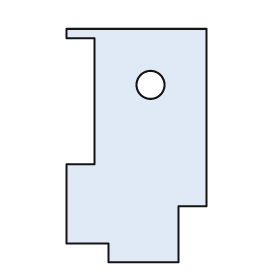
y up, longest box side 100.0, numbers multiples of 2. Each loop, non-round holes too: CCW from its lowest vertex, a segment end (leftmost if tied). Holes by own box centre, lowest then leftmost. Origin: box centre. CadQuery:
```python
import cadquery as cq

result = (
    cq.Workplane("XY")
    .moveTo(-12.0, -50.0)
    .lineTo(18.0, -50.0)
    .lineTo(18.0, -26.0)
    .lineTo(30.0, -26.0)
    .lineTo(30.0, 50.0)
    .lineTo(-30.0, 50.0)
    .lineTo(-30.0, 46.0)
    .lineTo(-18.0, 46.0)
    .lineTo(-18.0, -8.0)
    .lineTo(-30.0, -8.0)
    .lineTo(-30.0, -42.0)
    .lineTo(-12.0, -42.0)
    .close()
    .moveTo(6.0, 26.0)
    .circle(6.0)
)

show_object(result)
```